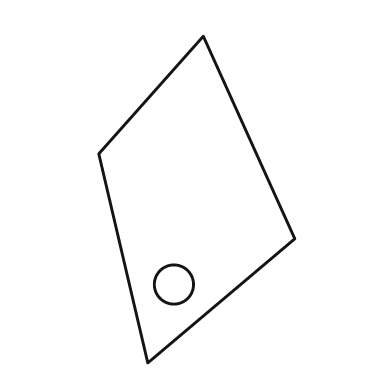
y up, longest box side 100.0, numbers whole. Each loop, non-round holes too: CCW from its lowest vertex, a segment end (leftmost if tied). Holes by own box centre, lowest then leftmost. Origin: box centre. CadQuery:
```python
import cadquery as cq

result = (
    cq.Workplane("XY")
    .moveTo(-15.0, -50.0)
    .lineTo(30.0, -12.0)
    .lineTo(2.0, 50.0)
    .lineTo(-30.0, 14.0)
    .close()
    .moveTo(-7.0, -26.0)
    .circle(6.0)
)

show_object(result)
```